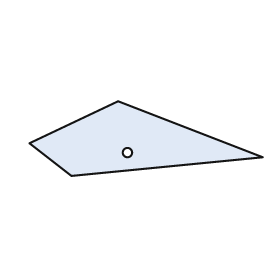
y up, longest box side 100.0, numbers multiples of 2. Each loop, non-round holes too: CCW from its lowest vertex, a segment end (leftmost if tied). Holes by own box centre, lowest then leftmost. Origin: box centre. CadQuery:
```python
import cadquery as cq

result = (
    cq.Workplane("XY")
    .moveTo(-32.0, -16.0)
    .lineTo(50.0, -8.0)
    .lineTo(-12.0, 16.0)
    .lineTo(-50.0, -2.0)
    .close()
    .moveTo(-8.0, -6.0)
    .circle(2.0)
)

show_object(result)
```